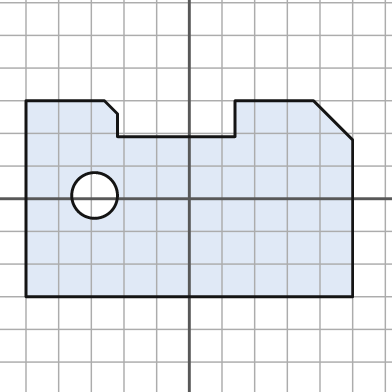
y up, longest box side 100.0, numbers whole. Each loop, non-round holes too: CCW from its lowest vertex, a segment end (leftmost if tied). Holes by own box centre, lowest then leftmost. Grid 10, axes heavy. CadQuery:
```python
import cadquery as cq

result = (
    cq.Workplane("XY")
    .moveTo(-50.0, -30.0)
    .lineTo(50.0, -30.0)
    .lineTo(50.0, 18.0)
    .lineTo(38.0, 30.0)
    .lineTo(14.0, 30.0)
    .lineTo(14.0, 19.0)
    .lineTo(-22.0, 19.0)
    .lineTo(-22.0, 26.0)
    .lineTo(-26.0, 30.0)
    .lineTo(-50.0, 30.0)
    .close()
    .moveTo(-29.0, 1.0)
    .circle(7.0)
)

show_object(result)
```